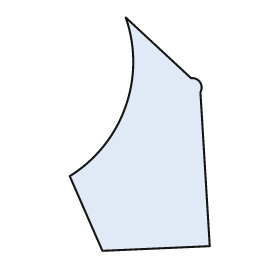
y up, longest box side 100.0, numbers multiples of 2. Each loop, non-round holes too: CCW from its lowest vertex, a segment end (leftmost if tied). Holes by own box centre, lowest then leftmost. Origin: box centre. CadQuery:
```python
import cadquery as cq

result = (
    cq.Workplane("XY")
    .moveTo(-16.0, -50.0)
    .lineTo(30.0, -48.0)
    .lineTo(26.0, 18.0)
    .threePointArc((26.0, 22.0), (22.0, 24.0))
    .lineTo(-6.0, 50.0)
    .threePointArc((-6.0, 12.0), (-30.0, -18.0))
    .close()
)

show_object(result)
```